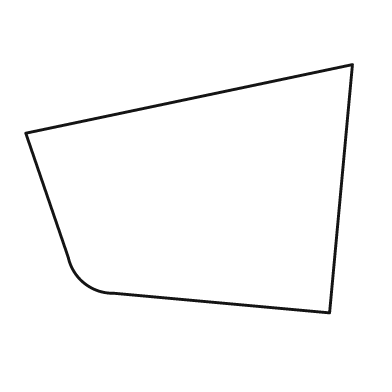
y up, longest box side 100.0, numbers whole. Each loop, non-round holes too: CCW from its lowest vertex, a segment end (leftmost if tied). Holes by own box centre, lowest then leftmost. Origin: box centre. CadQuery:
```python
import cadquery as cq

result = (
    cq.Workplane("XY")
    .moveTo(43.0, -38.0)
    .lineTo(50.0, 38.0)
    .lineTo(-50.0, 17.0)
    .lineTo(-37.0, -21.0)
    .threePointArc((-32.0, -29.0), (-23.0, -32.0))
    .close()
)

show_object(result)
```